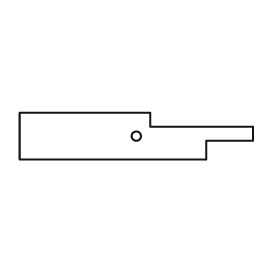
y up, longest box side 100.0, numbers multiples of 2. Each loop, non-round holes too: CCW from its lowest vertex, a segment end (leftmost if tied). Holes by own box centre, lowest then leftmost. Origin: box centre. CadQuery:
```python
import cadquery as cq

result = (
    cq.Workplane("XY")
    .moveTo(-50.0, -10.0)
    .lineTo(30.0, -10.0)
    .lineTo(30.0, -2.0)
    .lineTo(50.0, -2.0)
    .lineTo(50.0, 4.0)
    .lineTo(6.0, 4.0)
    .lineTo(6.0, 10.0)
    .lineTo(-50.0, 10.0)
    .close()
    .moveTo(0.0, 0.0)
    .circle(2.0)
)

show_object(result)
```